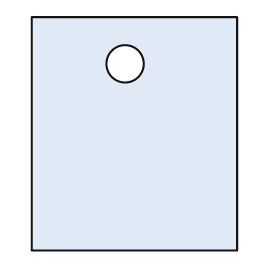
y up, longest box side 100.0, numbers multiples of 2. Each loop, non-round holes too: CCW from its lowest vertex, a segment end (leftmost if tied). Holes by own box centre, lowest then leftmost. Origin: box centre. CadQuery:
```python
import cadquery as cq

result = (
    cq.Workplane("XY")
    .moveTo(-44.0, -50.0)
    .lineTo(44.0, -50.0)
    .lineTo(44.0, 50.0)
    .lineTo(-44.0, 50.0)
    .close()
    .moveTo(-4.0, 30.0)
    .circle(8.0)
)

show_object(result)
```